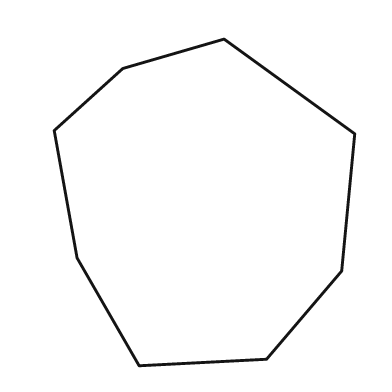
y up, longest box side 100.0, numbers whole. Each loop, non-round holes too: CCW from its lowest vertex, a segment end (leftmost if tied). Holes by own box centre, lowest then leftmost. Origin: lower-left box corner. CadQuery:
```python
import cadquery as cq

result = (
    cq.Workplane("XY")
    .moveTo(26.0, 0.0)
    .lineTo(65.0, 2.0)
    .lineTo(88.0, 29.0)
    .lineTo(92.0, 71.0)
    .lineTo(52.0, 100.0)
    .lineTo(21.0, 91.0)
    .lineTo(0.0, 72.0)
    .lineTo(7.0, 33.0)
    .close()
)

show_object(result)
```